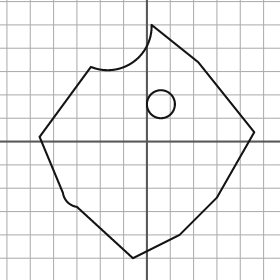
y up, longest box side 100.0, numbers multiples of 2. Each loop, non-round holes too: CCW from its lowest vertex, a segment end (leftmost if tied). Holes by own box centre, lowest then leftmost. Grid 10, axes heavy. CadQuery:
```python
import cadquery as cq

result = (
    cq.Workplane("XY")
    .moveTo(-6.0, -50.0)
    .lineTo(14.0, -40.0)
    .lineTo(30.0, -24.0)
    .lineTo(46.0, 4.0)
    .lineTo(22.0, 34.0)
    .lineTo(2.0, 50.0)
    .threePointArc((-6.0, 34.0), (-24.0, 32.0))
    .lineTo(-46.0, 2.0)
    .lineTo(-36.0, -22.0)
    .threePointArc((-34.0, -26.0), (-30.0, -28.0))
    .close()
    .moveTo(6.0, 16.0)
    .circle(6.0)
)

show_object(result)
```